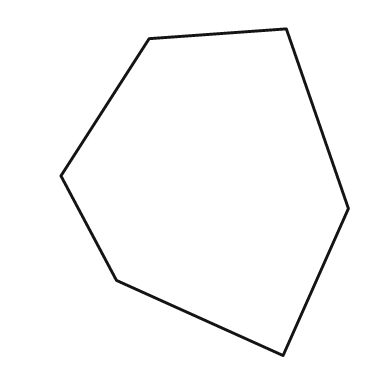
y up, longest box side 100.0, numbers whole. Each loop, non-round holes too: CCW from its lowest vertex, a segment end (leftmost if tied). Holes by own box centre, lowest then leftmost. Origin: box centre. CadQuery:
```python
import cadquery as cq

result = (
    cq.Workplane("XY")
    .moveTo(24.0, -50.0)
    .lineTo(44.0, -5.0)
    .lineTo(25.0, 50.0)
    .lineTo(-17.0, 47.0)
    .lineTo(-44.0, 5.0)
    .lineTo(-27.0, -27.0)
    .close()
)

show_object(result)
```